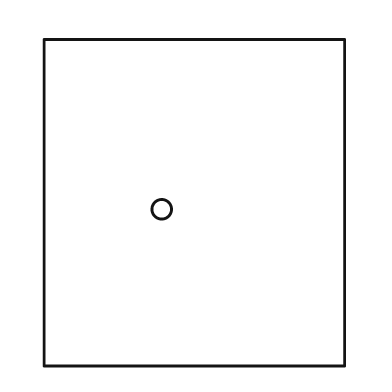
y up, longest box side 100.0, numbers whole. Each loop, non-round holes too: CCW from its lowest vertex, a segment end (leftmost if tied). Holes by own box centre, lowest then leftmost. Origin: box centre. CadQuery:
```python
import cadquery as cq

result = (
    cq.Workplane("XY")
    .moveTo(-46.0, -50.0)
    .lineTo(46.0, -50.0)
    .lineTo(46.0, 50.0)
    .lineTo(-46.0, 50.0)
    .close()
    .moveTo(-10.0, -2.0)
    .circle(3.0)
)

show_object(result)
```